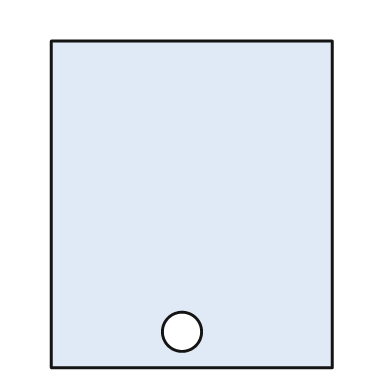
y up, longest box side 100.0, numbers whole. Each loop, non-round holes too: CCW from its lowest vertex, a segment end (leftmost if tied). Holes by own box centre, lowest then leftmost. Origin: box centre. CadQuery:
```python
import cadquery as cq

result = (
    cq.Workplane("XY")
    .moveTo(-43.0, -50.0)
    .lineTo(43.0, -50.0)
    .lineTo(43.0, 50.0)
    .lineTo(-43.0, 50.0)
    .close()
    .moveTo(-3.0, -39.0)
    .circle(6.0)
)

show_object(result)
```